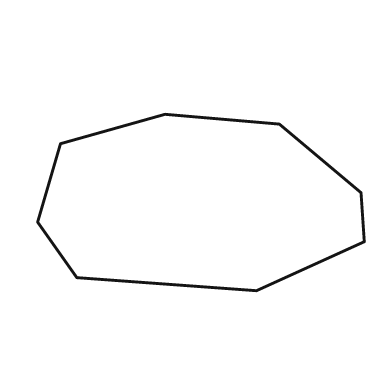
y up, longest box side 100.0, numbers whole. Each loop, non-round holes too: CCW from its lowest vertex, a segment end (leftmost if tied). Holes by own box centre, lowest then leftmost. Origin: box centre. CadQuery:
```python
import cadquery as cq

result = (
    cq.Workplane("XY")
    .moveTo(17.0, -27.0)
    .lineTo(50.0, -12.0)
    .lineTo(49.0, 3.0)
    .lineTo(24.0, 24.0)
    .lineTo(-11.0, 27.0)
    .lineTo(-43.0, 18.0)
    .lineTo(-50.0, -6.0)
    .lineTo(-38.0, -23.0)
    .close()
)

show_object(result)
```